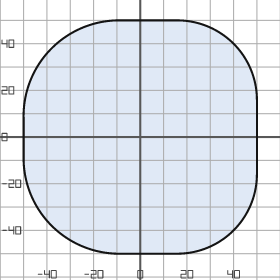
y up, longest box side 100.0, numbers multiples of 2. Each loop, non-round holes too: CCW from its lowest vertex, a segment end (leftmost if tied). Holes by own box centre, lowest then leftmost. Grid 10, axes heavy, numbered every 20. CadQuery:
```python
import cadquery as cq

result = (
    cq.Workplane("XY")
    .moveTo(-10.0, -50.0)
    .lineTo(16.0, -50.0)
    .threePointArc((40.0, -40.0), (50.0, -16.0))
    .lineTo(50.0, 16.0)
    .threePointArc((40.0, 40.0), (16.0, 50.0))
    .lineTo(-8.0, 50.0)
    .threePointArc((-38.0, 38.0), (-50.0, 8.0))
    .lineTo(-50.0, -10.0)
    .threePointArc((-38.0, -38.0), (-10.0, -50.0))
    .close()
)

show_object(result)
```